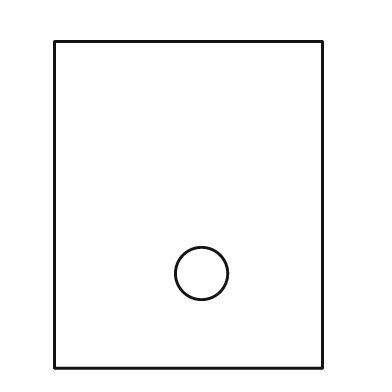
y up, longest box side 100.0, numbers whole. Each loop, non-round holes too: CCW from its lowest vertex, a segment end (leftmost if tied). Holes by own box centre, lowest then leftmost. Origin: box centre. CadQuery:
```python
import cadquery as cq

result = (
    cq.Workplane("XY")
    .moveTo(-41.0, -50.0)
    .lineTo(41.0, -50.0)
    .lineTo(41.0, 50.0)
    .lineTo(-41.0, 50.0)
    .close()
    .moveTo(4.0, -21.0)
    .circle(8.0)
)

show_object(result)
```